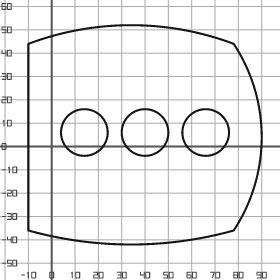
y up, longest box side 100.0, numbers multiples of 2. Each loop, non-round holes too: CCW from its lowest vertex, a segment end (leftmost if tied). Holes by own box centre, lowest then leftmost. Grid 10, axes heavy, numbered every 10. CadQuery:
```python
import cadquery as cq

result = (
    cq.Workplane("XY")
    .moveTo(-10.0, -36.0)
    .threePointArc((34.0, -42.0), (78.0, -36.0))
    .threePointArc((90.0, 4.0), (78.0, 44.0))
    .threePointArc((34.0, 52.0), (-10.0, 44.0))
    .close()
    .moveTo(14.0, 6.0)
    .circle(10.0)
    .moveTo(40.0, 6.0)
    .circle(10.0)
    .moveTo(66.0, 6.0)
    .circle(10.0)
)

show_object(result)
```